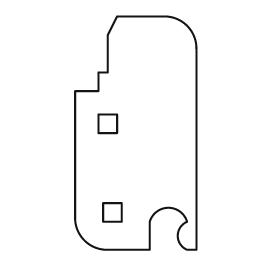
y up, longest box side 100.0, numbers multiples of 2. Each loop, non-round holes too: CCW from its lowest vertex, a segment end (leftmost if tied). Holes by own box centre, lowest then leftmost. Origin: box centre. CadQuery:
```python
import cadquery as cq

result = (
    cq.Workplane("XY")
    .moveTo(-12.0, -50.0)
    .lineTo(6.0, -50.0)
    .lineTo(6.0, -38.0)
    .threePointArc((14.0, -32.0), (22.0, -38.0))
    .threePointArc((18.0, -44.0), (22.0, -50.0))
    .lineTo(26.0, -50.0)
    .lineTo(26.0, 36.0)
    .threePointArc((22.0, 46.0), (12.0, 50.0))
    .lineTo(-8.0, 50.0)
    .lineTo(-12.0, 42.0)
    .lineTo(-12.0, 26.0)
    .lineTo(-16.0, 26.0)
    .lineTo(-16.0, 18.0)
    .lineTo(-26.0, 18.0)
    .lineTo(-26.0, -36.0)
    .threePointArc((-22.0, -46.0), (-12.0, -50.0))
    .close()
    .moveTo(-14.0, -38.0)
    .lineTo(-6.0, -38.0)
    .lineTo(-6.0, -30.0)
    .lineTo(-14.0, -30.0)
    .close()
    .moveTo(-16.0, 0.0)
    .lineTo(-8.0, 0.0)
    .lineTo(-8.0, 8.0)
    .lineTo(-16.0, 8.0)
    .close()
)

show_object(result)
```